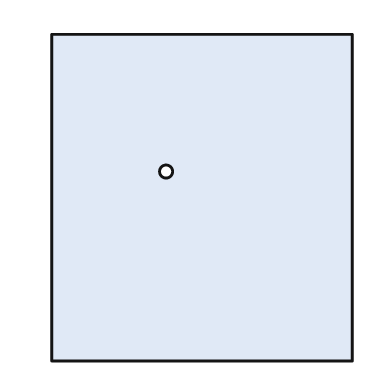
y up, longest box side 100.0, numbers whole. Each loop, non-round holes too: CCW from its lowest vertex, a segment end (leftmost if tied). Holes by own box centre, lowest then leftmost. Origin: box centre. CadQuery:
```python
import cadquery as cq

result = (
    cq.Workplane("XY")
    .moveTo(-46.0, -50.0)
    .lineTo(46.0, -50.0)
    .lineTo(46.0, 50.0)
    .lineTo(-46.0, 50.0)
    .close()
    .moveTo(-11.0, 8.0)
    .circle(2.0)
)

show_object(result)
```